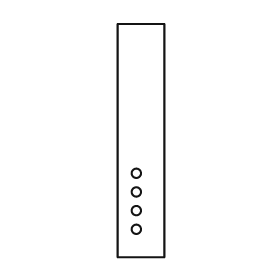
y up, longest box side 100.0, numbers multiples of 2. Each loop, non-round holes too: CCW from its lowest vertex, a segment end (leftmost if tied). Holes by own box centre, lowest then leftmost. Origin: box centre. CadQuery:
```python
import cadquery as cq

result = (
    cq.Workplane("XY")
    .moveTo(-10.0, -50.0)
    .lineTo(10.0, -50.0)
    .lineTo(10.0, 50.0)
    .lineTo(-10.0, 50.0)
    .close()
    .moveTo(-2.0, -38.0)
    .circle(2.0)
    .moveTo(-2.0, -30.0)
    .circle(2.0)
    .moveTo(-2.0, -22.0)
    .circle(2.0)
    .moveTo(-2.0, -14.0)
    .circle(2.0)
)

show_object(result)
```